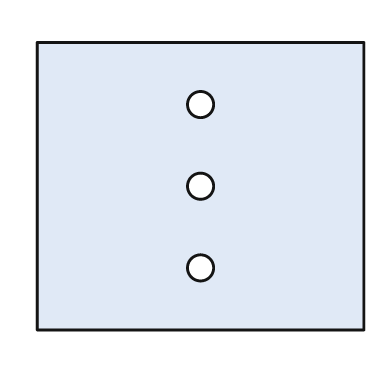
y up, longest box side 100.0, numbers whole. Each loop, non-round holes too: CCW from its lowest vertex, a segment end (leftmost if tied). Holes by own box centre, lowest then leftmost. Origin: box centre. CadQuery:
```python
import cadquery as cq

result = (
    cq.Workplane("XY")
    .moveTo(-50.0, -44.0)
    .lineTo(50.0, -44.0)
    .lineTo(50.0, 44.0)
    .lineTo(-50.0, 44.0)
    .close()
    .moveTo(0.0, -25.0)
    .circle(4.0)
    .moveTo(0.0, 0.0)
    .circle(4.0)
    .moveTo(0.0, 25.0)
    .circle(4.0)
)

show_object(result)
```